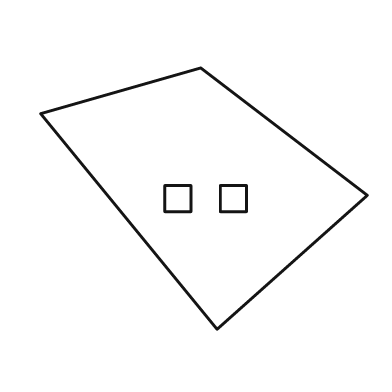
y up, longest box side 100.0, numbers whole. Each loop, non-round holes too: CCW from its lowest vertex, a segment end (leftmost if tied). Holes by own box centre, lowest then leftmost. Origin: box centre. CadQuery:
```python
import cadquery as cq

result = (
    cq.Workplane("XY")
    .moveTo(4.0, -40.0)
    .lineTo(50.0, 1.0)
    .lineTo(-1.0, 40.0)
    .lineTo(-50.0, 26.0)
    .close()
    .moveTo(-12.0, -4.0)
    .lineTo(-4.0, -4.0)
    .lineTo(-4.0, 4.0)
    .lineTo(-12.0, 4.0)
    .close()
    .moveTo(5.0, -4.0)
    .lineTo(13.0, -4.0)
    .lineTo(13.0, 4.0)
    .lineTo(5.0, 4.0)
    .close()
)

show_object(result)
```